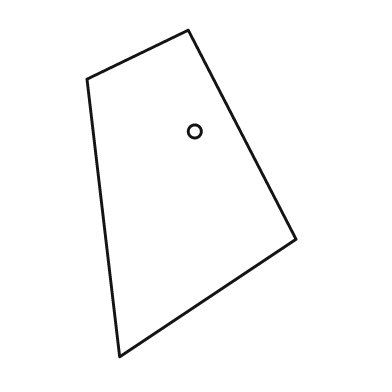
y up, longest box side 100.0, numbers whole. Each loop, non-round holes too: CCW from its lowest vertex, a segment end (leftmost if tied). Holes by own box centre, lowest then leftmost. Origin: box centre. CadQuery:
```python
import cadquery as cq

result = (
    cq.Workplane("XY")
    .moveTo(-22.0, -50.0)
    .lineTo(32.0, -14.0)
    .lineTo(-1.0, 50.0)
    .lineTo(-32.0, 35.0)
    .close()
    .moveTo(1.0, 19.0)
    .circle(2.0)
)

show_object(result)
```